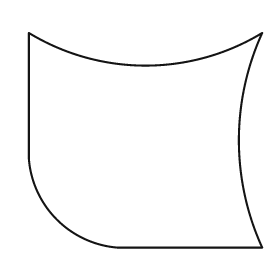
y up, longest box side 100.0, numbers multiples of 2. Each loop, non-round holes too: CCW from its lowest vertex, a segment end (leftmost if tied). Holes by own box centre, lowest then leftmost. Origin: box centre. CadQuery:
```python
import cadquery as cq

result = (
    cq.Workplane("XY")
    .moveTo(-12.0, -46.0)
    .lineTo(50.0, -46.0)
    .threePointArc((40.0, 0.0), (50.0, 46.0))
    .threePointArc((0.0, 32.0), (-50.0, 46.0))
    .lineTo(-50.0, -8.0)
    .threePointArc((-38.0, -34.0), (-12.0, -46.0))
    .close()
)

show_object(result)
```